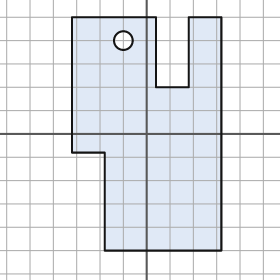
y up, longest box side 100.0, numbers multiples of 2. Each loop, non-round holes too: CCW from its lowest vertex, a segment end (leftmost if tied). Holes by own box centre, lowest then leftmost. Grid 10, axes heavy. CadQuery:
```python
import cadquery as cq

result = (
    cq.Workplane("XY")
    .moveTo(-18.0, -50.0)
    .lineTo(32.0, -50.0)
    .lineTo(32.0, 50.0)
    .lineTo(18.0, 50.0)
    .lineTo(18.0, 20.0)
    .lineTo(4.0, 20.0)
    .lineTo(4.0, 50.0)
    .lineTo(-32.0, 50.0)
    .lineTo(-32.0, -8.0)
    .lineTo(-18.0, -8.0)
    .close()
    .moveTo(-10.0, 40.0)
    .circle(4.0)
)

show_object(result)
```